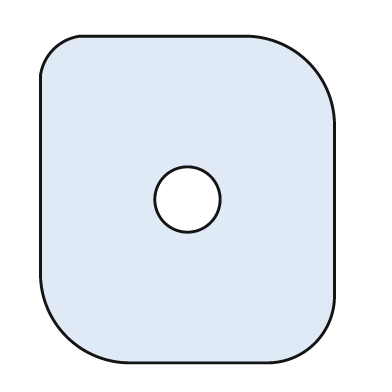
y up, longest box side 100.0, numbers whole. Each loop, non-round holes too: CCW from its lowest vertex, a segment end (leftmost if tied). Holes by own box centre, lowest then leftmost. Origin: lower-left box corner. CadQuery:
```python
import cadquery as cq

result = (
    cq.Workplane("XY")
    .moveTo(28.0, 0.0)
    .lineTo(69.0, 0.0)
    .threePointArc((84.0, 6.0), (90.0, 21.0))
    .lineTo(90.0, 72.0)
    .threePointArc((82.0, 92.0), (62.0, 100.0))
    .lineTo(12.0, 100.0)
    .threePointArc((4.0, 96.0), (0.0, 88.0))
    .lineTo(0.0, 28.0)
    .threePointArc((8.0, 8.0), (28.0, 0.0))
    .close()
    .moveTo(45.0, 50.0)
    .circle(10.0)
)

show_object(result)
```